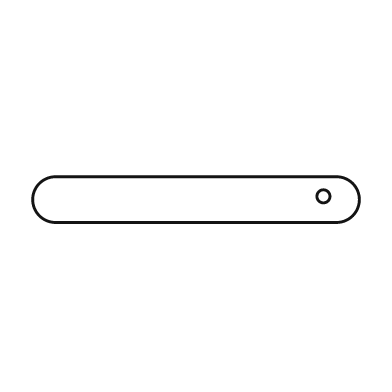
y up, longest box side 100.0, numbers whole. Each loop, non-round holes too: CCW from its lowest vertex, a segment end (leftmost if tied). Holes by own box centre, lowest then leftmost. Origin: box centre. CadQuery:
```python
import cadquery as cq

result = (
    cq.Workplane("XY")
    .moveTo(-43.0, -7.0)
    .lineTo(43.0, -7.0)
    .threePointArc((50.0, 0.0), (43.0, 7.0))
    .lineTo(-43.0, 7.0)
    .threePointArc((-50.0, 0.0), (-43.0, -7.0))
    .close()
    .moveTo(39.0, 1.0)
    .circle(2.0)
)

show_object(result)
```